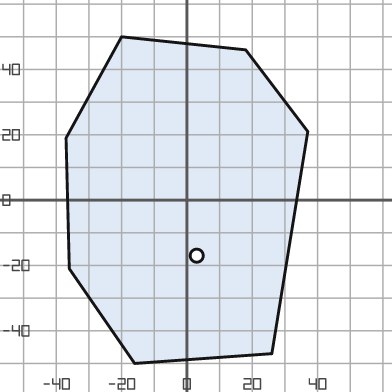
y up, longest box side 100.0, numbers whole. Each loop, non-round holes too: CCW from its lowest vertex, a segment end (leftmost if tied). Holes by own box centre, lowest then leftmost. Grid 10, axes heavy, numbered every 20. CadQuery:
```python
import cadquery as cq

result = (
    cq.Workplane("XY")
    .moveTo(-16.0, -50.0)
    .lineTo(26.0, -47.0)
    .lineTo(37.0, 21.0)
    .lineTo(18.0, 46.0)
    .lineTo(-20.0, 50.0)
    .lineTo(-37.0, 19.0)
    .lineTo(-36.0, -21.0)
    .close()
    .moveTo(3.0, -17.0)
    .circle(2.0)
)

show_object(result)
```